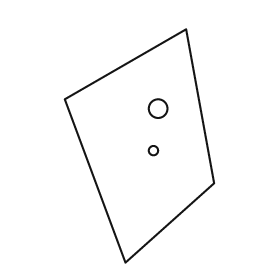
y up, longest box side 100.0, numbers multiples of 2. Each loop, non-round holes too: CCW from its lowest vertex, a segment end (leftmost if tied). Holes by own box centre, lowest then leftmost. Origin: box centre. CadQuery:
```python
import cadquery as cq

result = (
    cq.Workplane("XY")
    .moveTo(-6.0, -50.0)
    .lineTo(32.0, -16.0)
    .lineTo(20.0, 50.0)
    .lineTo(-32.0, 20.0)
    .close()
    .moveTo(6.0, -2.0)
    .circle(2.0)
    .moveTo(8.0, 16.0)
    .circle(4.0)
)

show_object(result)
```